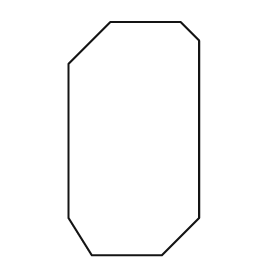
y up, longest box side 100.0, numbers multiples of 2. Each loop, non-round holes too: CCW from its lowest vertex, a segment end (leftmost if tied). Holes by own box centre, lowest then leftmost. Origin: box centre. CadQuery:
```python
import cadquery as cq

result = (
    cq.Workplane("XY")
    .moveTo(-18.0, -50.0)
    .lineTo(12.0, -50.0)
    .lineTo(28.0, -34.0)
    .lineTo(28.0, 42.0)
    .lineTo(20.0, 50.0)
    .lineTo(-10.0, 50.0)
    .lineTo(-28.0, 32.0)
    .lineTo(-28.0, -34.0)
    .close()
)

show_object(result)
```